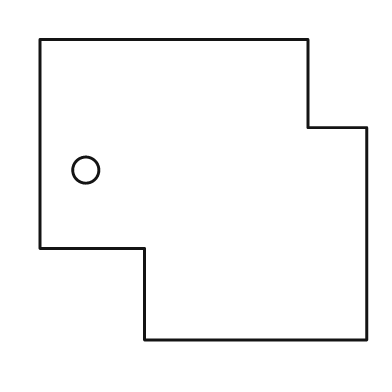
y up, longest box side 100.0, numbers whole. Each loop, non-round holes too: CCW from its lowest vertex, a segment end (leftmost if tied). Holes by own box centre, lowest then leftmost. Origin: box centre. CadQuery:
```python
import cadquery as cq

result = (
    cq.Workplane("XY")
    .moveTo(-18.0, -46.0)
    .lineTo(50.0, -46.0)
    .lineTo(50.0, 19.0)
    .lineTo(32.0, 19.0)
    .lineTo(32.0, 46.0)
    .lineTo(-50.0, 46.0)
    .lineTo(-50.0, -18.0)
    .lineTo(-18.0, -18.0)
    .close()
    .moveTo(-36.0, 6.0)
    .circle(4.0)
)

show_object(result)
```